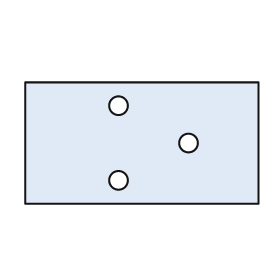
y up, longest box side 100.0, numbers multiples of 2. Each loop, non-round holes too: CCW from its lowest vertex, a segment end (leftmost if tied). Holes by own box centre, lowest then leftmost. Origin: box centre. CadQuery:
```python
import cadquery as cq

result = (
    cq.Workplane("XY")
    .moveTo(-50.0, -26.0)
    .lineTo(50.0, -26.0)
    .lineTo(50.0, 26.0)
    .lineTo(-50.0, 26.0)
    .close()
    .moveTo(-10.0, -16.0)
    .circle(4.0)
    .moveTo(20.0, 0.0)
    .circle(4.0)
    .moveTo(-10.0, 16.0)
    .circle(4.0)
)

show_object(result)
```